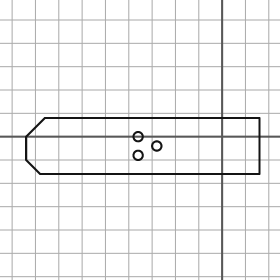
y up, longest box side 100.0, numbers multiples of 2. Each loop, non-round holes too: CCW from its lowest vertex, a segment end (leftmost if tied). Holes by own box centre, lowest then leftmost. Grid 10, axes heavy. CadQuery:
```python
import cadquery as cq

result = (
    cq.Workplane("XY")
    .moveTo(-78.0, -16.0)
    .lineTo(16.0, -16.0)
    .lineTo(16.0, 8.0)
    .lineTo(-76.0, 8.0)
    .lineTo(-84.0, 0.0)
    .lineTo(-84.0, -10.0)
    .close()
    .moveTo(-36.0, -8.0)
    .circle(2.0)
    .moveTo(-28.0, -4.0)
    .circle(2.0)
    .moveTo(-36.0, 0.0)
    .circle(2.0)
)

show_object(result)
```